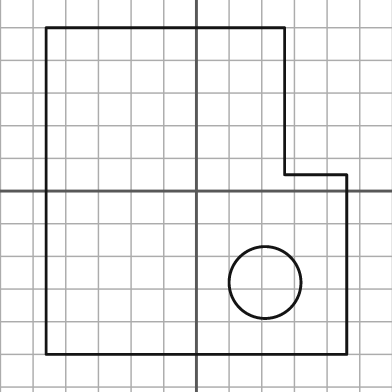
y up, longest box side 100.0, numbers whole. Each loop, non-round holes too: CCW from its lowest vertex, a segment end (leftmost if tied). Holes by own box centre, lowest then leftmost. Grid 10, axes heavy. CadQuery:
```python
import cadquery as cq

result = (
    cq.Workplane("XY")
    .moveTo(-46.0, -50.0)
    .lineTo(46.0, -50.0)
    .lineTo(46.0, 5.0)
    .lineTo(27.0, 5.0)
    .lineTo(27.0, 50.0)
    .lineTo(-46.0, 50.0)
    .close()
    .moveTo(21.0, -28.0)
    .circle(11.0)
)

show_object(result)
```